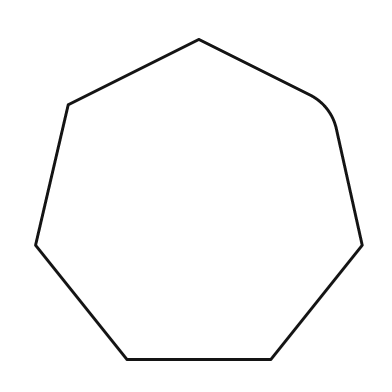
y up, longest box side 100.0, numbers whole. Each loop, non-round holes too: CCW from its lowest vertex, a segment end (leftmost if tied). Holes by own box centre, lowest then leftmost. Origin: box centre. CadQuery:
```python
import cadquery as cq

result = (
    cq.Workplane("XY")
    .moveTo(-22.0, -49.0)
    .lineTo(22.0, -49.0)
    .lineTo(50.0, -14.0)
    .lineTo(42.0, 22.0)
    .threePointArc((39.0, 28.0), (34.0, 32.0))
    .lineTo(0.0, 49.0)
    .lineTo(-40.0, 29.0)
    .lineTo(-50.0, -14.0)
    .close()
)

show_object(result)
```